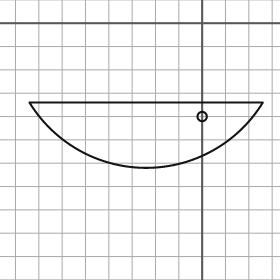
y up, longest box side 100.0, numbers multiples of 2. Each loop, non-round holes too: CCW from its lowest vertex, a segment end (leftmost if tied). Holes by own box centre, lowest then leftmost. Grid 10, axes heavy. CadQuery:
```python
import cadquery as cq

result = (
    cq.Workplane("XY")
    .moveTo(-74.0, -34.0)
    .threePointArc((-24.0, -62.0), (26.0, -34.0))
    .close()
    .moveTo(0.0, -40.0)
    .circle(2.0)
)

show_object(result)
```